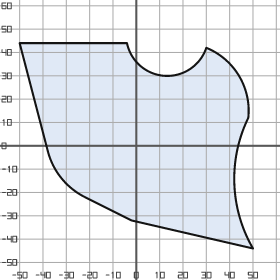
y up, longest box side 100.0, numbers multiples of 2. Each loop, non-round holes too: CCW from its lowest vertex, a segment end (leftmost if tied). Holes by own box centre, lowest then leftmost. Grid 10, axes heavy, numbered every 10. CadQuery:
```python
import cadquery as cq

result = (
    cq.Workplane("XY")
    .moveTo(50.0, -44.0)
    .threePointArc((42.0, -16.0), (48.0, 12.0))
    .threePointArc((44.0, 30.0), (30.0, 42.0))
    .threePointArc((12.0, 30.0), (-4.0, 44.0))
    .lineTo(-50.0, 44.0)
    .lineTo(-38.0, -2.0)
    .threePointArc((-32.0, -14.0), (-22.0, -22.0))
    .lineTo(-2.0, -32.0)
    .close()
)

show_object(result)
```